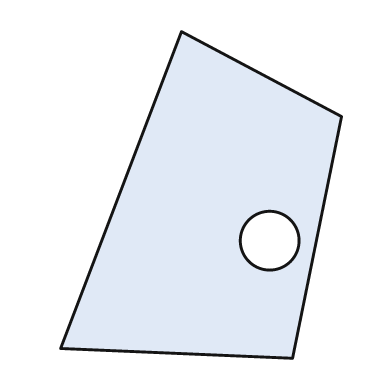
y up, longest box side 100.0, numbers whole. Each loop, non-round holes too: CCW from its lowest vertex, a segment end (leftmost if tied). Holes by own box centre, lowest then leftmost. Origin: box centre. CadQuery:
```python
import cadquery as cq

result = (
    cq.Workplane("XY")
    .moveTo(28.0, -50.0)
    .lineTo(43.0, 24.0)
    .lineTo(-6.0, 50.0)
    .lineTo(-43.0, -47.0)
    .close()
    .moveTo(21.0, -14.0)
    .circle(9.0)
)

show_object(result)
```